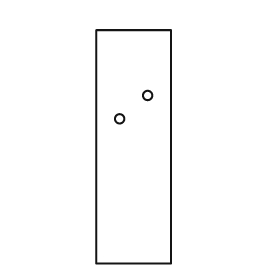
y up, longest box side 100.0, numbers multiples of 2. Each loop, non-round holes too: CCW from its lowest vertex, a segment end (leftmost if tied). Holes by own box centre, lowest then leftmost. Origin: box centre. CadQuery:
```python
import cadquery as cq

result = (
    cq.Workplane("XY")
    .moveTo(-16.0, -50.0)
    .lineTo(16.0, -50.0)
    .lineTo(16.0, 50.0)
    .lineTo(-16.0, 50.0)
    .close()
    .moveTo(-6.0, 12.0)
    .circle(2.0)
    .moveTo(6.0, 22.0)
    .circle(2.0)
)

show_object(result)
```